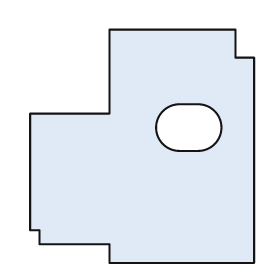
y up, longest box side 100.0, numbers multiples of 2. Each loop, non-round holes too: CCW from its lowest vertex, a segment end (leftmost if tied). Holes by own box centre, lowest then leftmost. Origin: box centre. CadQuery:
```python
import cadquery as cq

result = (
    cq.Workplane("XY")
    .moveTo(-14.0, -50.0)
    .lineTo(48.0, -50.0)
    .lineTo(48.0, 38.0)
    .lineTo(40.0, 38.0)
    .lineTo(40.0, 50.0)
    .lineTo(-14.0, 50.0)
    .lineTo(-14.0, 14.0)
    .lineTo(-48.0, 14.0)
    .lineTo(-48.0, -36.0)
    .lineTo(-44.0, -36.0)
    .lineTo(-44.0, -42.0)
    .lineTo(-14.0, -42.0)
    .close()
    .moveTo(16.0, -2.0)
    .lineTo(24.0, -2.0)
    .threePointArc((34.0, 8.0), (24.0, 18.0))
    .lineTo(16.0, 18.0)
    .threePointArc((6.0, 8.0), (16.0, -2.0))
    .close()
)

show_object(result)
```